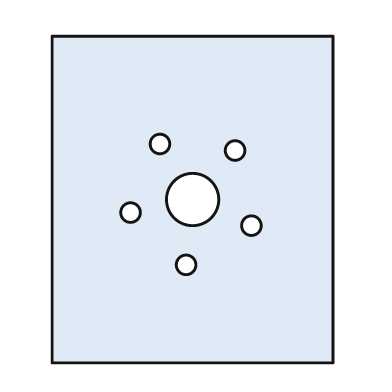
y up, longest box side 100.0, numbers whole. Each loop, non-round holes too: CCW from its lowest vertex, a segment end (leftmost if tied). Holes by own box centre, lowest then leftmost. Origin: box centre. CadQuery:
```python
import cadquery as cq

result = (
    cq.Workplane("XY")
    .moveTo(-43.0, -50.0)
    .lineTo(43.0, -50.0)
    .lineTo(43.0, 50.0)
    .lineTo(-43.0, 50.0)
    .close()
    .moveTo(-2.0, -20.0)
    .circle(3.0)
    .moveTo(18.0, -8.0)
    .circle(3.0)
    .moveTo(-19.0, -4.0)
    .circle(3.0)
    .moveTo(0.0, 0.0)
    .circle(8.0)
    .moveTo(13.0, 15.0)
    .circle(3.0)
    .moveTo(-10.0, 17.0)
    .circle(3.0)
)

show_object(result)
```